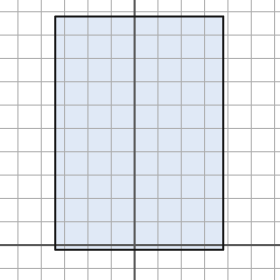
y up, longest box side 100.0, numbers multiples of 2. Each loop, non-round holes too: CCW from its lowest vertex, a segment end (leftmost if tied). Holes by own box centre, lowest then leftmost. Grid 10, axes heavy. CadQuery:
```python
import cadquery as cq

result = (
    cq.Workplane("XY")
    .moveTo(-34.0, -2.0)
    .lineTo(38.0, -2.0)
    .lineTo(38.0, 98.0)
    .lineTo(-34.0, 98.0)
    .close()
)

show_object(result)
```